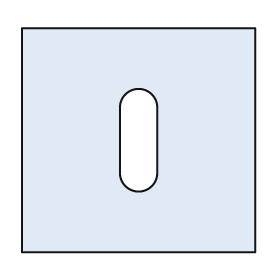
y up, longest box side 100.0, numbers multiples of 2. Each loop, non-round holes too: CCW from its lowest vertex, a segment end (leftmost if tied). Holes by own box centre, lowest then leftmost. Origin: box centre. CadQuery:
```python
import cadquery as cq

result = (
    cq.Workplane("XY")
    .moveTo(-50.0, -48.0)
    .lineTo(50.0, -48.0)
    .lineTo(50.0, 48.0)
    .lineTo(-50.0, 48.0)
    .close()
    .moveTo(-8.0, -14.0)
    .threePointArc((0.0, -22.0), (8.0, -14.0))
    .lineTo(8.0, 14.0)
    .threePointArc((0.0, 22.0), (-8.0, 14.0))
    .close()
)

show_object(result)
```